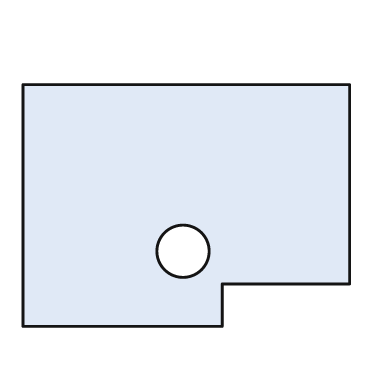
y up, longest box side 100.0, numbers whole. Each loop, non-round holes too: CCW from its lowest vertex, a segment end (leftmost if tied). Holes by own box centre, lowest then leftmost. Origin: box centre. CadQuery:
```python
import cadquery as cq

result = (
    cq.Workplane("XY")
    .moveTo(-50.0, -37.0)
    .lineTo(11.0, -37.0)
    .lineTo(11.0, -24.0)
    .lineTo(50.0, -24.0)
    .lineTo(50.0, 37.0)
    .lineTo(-50.0, 37.0)
    .close()
    .moveTo(-1.0, -14.0)
    .circle(8.0)
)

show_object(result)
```